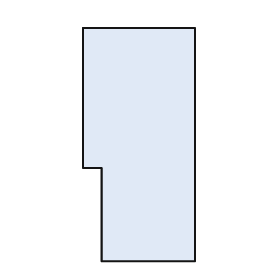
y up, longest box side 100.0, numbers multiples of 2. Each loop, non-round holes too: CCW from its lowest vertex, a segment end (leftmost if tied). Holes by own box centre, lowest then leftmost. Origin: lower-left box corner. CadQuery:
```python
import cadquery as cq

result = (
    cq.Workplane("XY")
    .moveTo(8.0, 0.0)
    .lineTo(48.0, 0.0)
    .lineTo(48.0, 100.0)
    .lineTo(0.0, 100.0)
    .lineTo(0.0, 40.0)
    .lineTo(8.0, 40.0)
    .close()
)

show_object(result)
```